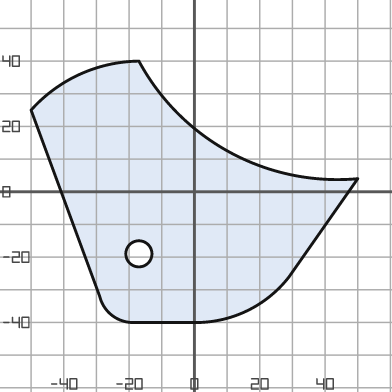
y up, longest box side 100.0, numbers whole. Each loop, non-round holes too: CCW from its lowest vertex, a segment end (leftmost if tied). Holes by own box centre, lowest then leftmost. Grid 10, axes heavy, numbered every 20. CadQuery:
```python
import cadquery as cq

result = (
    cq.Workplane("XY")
    .moveTo(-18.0, -40.0)
    .lineTo(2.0, -40.0)
    .threePointArc((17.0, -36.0), (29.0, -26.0))
    .lineTo(50.0, 4.0)
    .threePointArc((11.0, 12.0), (-17.0, 40.0))
    .threePointArc((-35.0, 36.0), (-50.0, 25.0))
    .lineTo(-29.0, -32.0)
    .threePointArc((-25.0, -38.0), (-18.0, -40.0))
    .close()
    .moveTo(-17.0, -19.0)
    .circle(4.0)
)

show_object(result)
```